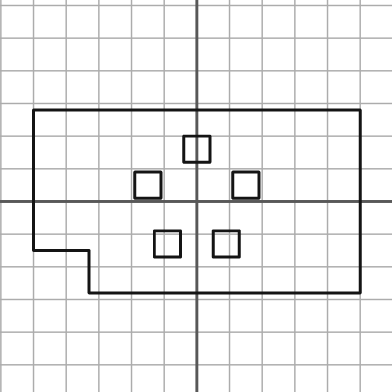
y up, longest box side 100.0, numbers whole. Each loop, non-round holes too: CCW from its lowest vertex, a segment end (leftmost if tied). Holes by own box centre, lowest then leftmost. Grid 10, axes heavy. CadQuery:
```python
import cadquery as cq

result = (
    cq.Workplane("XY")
    .moveTo(-33.0, -28.0)
    .lineTo(50.0, -28.0)
    .lineTo(50.0, 28.0)
    .lineTo(-50.0, 28.0)
    .lineTo(-50.0, -15.0)
    .lineTo(-33.0, -15.0)
    .close()
    .moveTo(-13.0, -17.0)
    .lineTo(-5.0, -17.0)
    .lineTo(-5.0, -9.0)
    .lineTo(-13.0, -9.0)
    .close()
    .moveTo(5.0, -17.0)
    .lineTo(13.0, -17.0)
    .lineTo(13.0, -9.0)
    .lineTo(5.0, -9.0)
    .close()
    .moveTo(-19.0, 1.0)
    .lineTo(-11.0, 1.0)
    .lineTo(-11.0, 9.0)
    .lineTo(-19.0, 9.0)
    .close()
    .moveTo(11.0, 1.0)
    .lineTo(19.0, 1.0)
    .lineTo(19.0, 9.0)
    .lineTo(11.0, 9.0)
    .close()
    .moveTo(-4.0, 12.0)
    .lineTo(4.0, 12.0)
    .lineTo(4.0, 20.0)
    .lineTo(-4.0, 20.0)
    .close()
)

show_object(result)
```